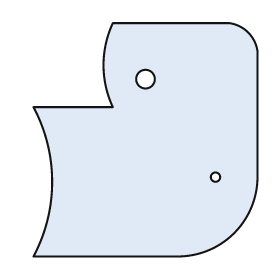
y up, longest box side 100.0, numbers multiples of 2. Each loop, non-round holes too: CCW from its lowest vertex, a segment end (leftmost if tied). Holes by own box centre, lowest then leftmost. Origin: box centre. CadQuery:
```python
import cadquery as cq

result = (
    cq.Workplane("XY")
    .moveTo(-48.0, -50.0)
    .lineTo(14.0, -50.0)
    .threePointArc((38.0, -40.0), (48.0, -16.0))
    .lineTo(48.0, 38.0)
    .threePointArc((44.0, 46.0), (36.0, 50.0))
    .lineTo(-14.0, 50.0)
    .threePointArc((-18.0, 32.0), (-14.0, 14.0))
    .lineTo(-48.0, 14.0)
    .threePointArc((-40.0, -18.0), (-48.0, -50.0))
    .close()
    .moveTo(30.0, -16.0)
    .circle(2.0)
    .moveTo(0.0, 26.0)
    .circle(4.0)
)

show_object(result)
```